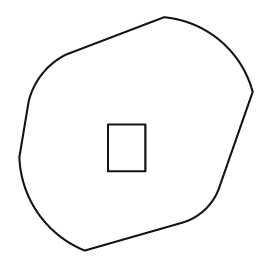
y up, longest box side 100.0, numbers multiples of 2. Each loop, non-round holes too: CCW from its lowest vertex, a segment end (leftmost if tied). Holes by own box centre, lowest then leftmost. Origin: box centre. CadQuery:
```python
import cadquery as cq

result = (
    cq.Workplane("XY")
    .moveTo(-22.0, -50.0)
    .lineTo(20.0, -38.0)
    .threePointArc((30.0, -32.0), (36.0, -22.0))
    .lineTo(50.0, 18.0)
    .threePointArc((36.0, 40.0), (12.0, 50.0))
    .lineTo(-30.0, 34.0)
    .threePointArc((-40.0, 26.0), (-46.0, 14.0))
    .lineTo(-50.0, -10.0)
    .threePointArc((-42.0, -34.0), (-22.0, -50.0))
    .close()
    .moveTo(-12.0, -16.0)
    .lineTo(4.0, -16.0)
    .lineTo(4.0, 4.0)
    .lineTo(-12.0, 4.0)
    .close()
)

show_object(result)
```